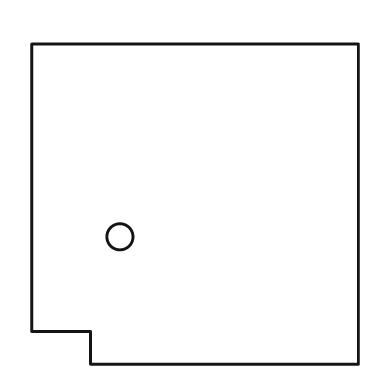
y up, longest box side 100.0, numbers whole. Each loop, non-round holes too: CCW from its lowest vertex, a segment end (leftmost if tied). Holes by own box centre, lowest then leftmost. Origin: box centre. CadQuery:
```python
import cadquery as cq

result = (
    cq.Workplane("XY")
    .moveTo(-32.0, -49.0)
    .lineTo(50.0, -49.0)
    .lineTo(50.0, 49.0)
    .lineTo(-50.0, 49.0)
    .lineTo(-50.0, -39.0)
    .lineTo(-32.0, -39.0)
    .close()
    .moveTo(-23.0, -10.0)
    .circle(4.0)
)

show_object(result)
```